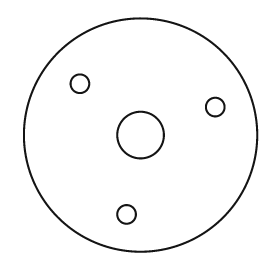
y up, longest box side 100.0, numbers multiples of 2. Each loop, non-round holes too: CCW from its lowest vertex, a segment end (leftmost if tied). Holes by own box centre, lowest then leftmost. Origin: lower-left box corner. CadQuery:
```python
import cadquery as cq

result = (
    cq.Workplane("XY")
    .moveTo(50.0, 50.0)
    .circle(50.0)
    .moveTo(44.0, 16.0)
    .circle(4.0)
    .moveTo(50.0, 50.0)
    .circle(10.0)
    .moveTo(82.0, 62.0)
    .circle(4.0)
    .moveTo(24.0, 72.0)
    .circle(4.0)
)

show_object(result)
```